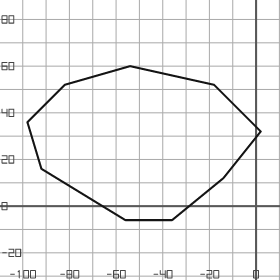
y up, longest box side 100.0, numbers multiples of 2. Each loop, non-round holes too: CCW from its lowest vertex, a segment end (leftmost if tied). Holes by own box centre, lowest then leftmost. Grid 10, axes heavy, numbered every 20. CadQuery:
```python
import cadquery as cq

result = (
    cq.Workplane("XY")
    .moveTo(-56.0, -6.0)
    .lineTo(-36.0, -6.0)
    .lineTo(-14.0, 12.0)
    .lineTo(2.0, 32.0)
    .lineTo(-18.0, 52.0)
    .lineTo(-54.0, 60.0)
    .lineTo(-82.0, 52.0)
    .lineTo(-98.0, 36.0)
    .lineTo(-92.0, 16.0)
    .close()
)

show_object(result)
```